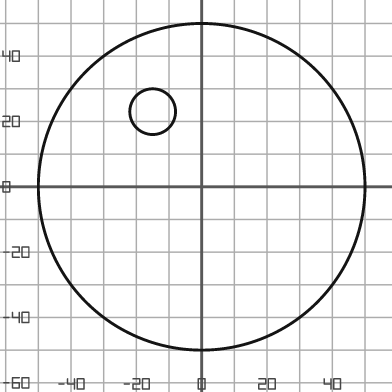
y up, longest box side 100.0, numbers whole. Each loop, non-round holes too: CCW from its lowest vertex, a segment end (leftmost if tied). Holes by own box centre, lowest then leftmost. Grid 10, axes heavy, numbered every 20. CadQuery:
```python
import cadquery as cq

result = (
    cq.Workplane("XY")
    .moveTo(0.0, 0.0)
    .circle(50.0)
    .moveTo(-15.0, 23.0)
    .circle(7.0)
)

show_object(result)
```